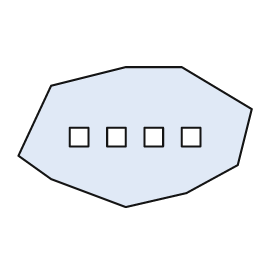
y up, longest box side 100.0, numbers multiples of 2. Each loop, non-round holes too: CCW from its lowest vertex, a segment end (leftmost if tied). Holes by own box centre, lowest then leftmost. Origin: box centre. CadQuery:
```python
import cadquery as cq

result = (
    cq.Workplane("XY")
    .moveTo(-4.0, -30.0)
    .lineTo(22.0, -24.0)
    .lineTo(44.0, -12.0)
    .lineTo(50.0, 12.0)
    .lineTo(20.0, 30.0)
    .lineTo(-4.0, 30.0)
    .lineTo(-36.0, 22.0)
    .lineTo(-50.0, -8.0)
    .lineTo(-36.0, -18.0)
    .close()
    .moveTo(-28.0, -4.0)
    .lineTo(-20.0, -4.0)
    .lineTo(-20.0, 4.0)
    .lineTo(-28.0, 4.0)
    .close()
    .moveTo(-12.0, -4.0)
    .lineTo(-4.0, -4.0)
    .lineTo(-4.0, 4.0)
    .lineTo(-12.0, 4.0)
    .close()
    .moveTo(4.0, -4.0)
    .lineTo(12.0, -4.0)
    .lineTo(12.0, 4.0)
    .lineTo(4.0, 4.0)
    .close()
    .moveTo(20.0, -4.0)
    .lineTo(28.0, -4.0)
    .lineTo(28.0, 4.0)
    .lineTo(20.0, 4.0)
    .close()
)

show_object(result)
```